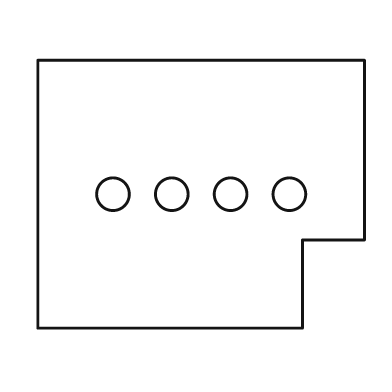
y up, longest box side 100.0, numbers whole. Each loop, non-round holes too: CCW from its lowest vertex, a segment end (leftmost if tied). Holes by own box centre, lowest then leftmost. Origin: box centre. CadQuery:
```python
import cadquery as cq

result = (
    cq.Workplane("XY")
    .moveTo(-50.0, -41.0)
    .lineTo(31.0, -41.0)
    .lineTo(31.0, -14.0)
    .lineTo(50.0, -14.0)
    .lineTo(50.0, 41.0)
    .lineTo(-50.0, 41.0)
    .close()
    .moveTo(-27.0, 0.0)
    .circle(5.0)
    .moveTo(-9.0, 0.0)
    .circle(5.0)
    .moveTo(9.0, 0.0)
    .circle(5.0)
    .moveTo(27.0, 0.0)
    .circle(5.0)
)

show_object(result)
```